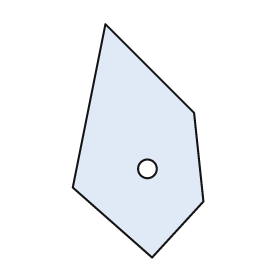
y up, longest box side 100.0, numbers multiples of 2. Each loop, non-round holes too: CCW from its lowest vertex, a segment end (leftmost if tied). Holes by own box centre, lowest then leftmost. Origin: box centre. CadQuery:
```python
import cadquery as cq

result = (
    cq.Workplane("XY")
    .moveTo(6.0, -50.0)
    .lineTo(28.0, -26.0)
    .lineTo(24.0, 12.0)
    .lineTo(-14.0, 50.0)
    .lineTo(-28.0, -20.0)
    .close()
    .moveTo(4.0, -12.0)
    .circle(4.0)
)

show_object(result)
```